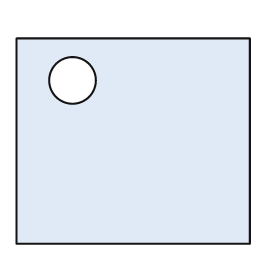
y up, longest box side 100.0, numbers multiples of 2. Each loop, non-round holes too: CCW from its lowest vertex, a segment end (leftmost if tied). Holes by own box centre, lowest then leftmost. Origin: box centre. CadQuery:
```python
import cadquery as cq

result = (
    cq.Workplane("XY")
    .moveTo(-50.0, -44.0)
    .lineTo(50.0, -44.0)
    .lineTo(50.0, 44.0)
    .lineTo(-50.0, 44.0)
    .close()
    .moveTo(-26.0, 26.0)
    .circle(10.0)
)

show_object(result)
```